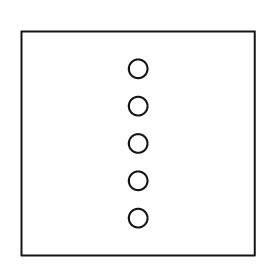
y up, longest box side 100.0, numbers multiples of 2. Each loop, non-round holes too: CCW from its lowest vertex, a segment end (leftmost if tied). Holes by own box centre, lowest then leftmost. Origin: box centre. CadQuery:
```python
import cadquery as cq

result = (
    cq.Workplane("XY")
    .moveTo(-50.0, -48.0)
    .lineTo(50.0, -48.0)
    .lineTo(50.0, 48.0)
    .lineTo(-50.0, 48.0)
    .close()
    .moveTo(0.0, -32.0)
    .circle(4.0)
    .moveTo(0.0, -16.0)
    .circle(4.0)
    .moveTo(0.0, 0.0)
    .circle(4.0)
    .moveTo(0.0, 16.0)
    .circle(4.0)
    .moveTo(0.0, 32.0)
    .circle(4.0)
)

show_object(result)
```